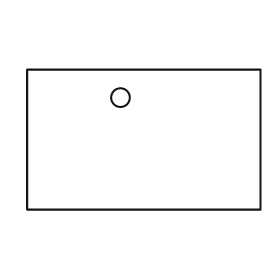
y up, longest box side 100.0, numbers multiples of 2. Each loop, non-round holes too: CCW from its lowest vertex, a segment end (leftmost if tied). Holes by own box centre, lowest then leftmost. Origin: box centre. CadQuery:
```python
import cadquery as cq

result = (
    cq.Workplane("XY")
    .moveTo(-50.0, -30.0)
    .lineTo(50.0, -30.0)
    .lineTo(50.0, 30.0)
    .lineTo(-50.0, 30.0)
    .close()
    .moveTo(-10.0, 18.0)
    .circle(4.0)
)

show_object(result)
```